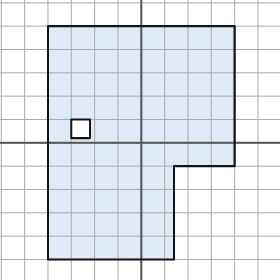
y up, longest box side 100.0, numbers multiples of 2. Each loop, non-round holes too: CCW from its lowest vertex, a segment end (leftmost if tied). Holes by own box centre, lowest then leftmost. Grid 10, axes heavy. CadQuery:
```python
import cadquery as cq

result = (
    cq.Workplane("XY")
    .moveTo(-40.0, -50.0)
    .lineTo(14.0, -50.0)
    .lineTo(14.0, -10.0)
    .lineTo(40.0, -10.0)
    .lineTo(40.0, 50.0)
    .lineTo(-40.0, 50.0)
    .close()
    .moveTo(-30.0, 2.0)
    .lineTo(-22.0, 2.0)
    .lineTo(-22.0, 10.0)
    .lineTo(-30.0, 10.0)
    .close()
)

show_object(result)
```